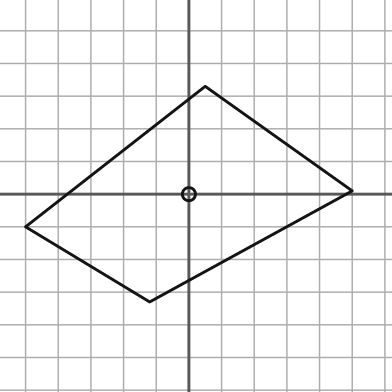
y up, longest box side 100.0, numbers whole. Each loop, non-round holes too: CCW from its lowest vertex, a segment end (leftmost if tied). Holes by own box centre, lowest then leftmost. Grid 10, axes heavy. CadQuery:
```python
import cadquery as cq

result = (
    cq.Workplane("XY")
    .moveTo(-12.0, -33.0)
    .lineTo(50.0, 1.0)
    .lineTo(5.0, 33.0)
    .lineTo(-50.0, -10.0)
    .close()
    .moveTo(0.0, 0.0)
    .circle(2.0)
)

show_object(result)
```